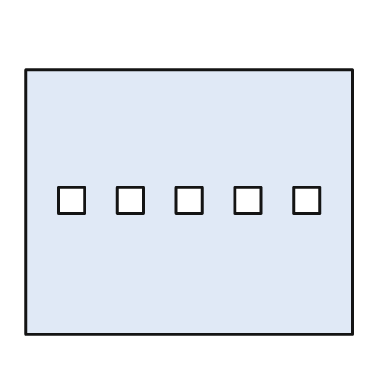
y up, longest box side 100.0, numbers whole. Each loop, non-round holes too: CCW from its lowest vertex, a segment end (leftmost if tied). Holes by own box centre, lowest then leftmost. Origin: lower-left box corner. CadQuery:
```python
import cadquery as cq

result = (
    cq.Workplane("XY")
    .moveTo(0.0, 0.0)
    .lineTo(100.0, 0.0)
    .lineTo(100.0, 81.0)
    .lineTo(0.0, 81.0)
    .close()
    .moveTo(10.0, 37.0)
    .lineTo(18.0, 37.0)
    .lineTo(18.0, 45.0)
    .lineTo(10.0, 45.0)
    .close()
    .moveTo(28.0, 37.0)
    .lineTo(36.0, 37.0)
    .lineTo(36.0, 45.0)
    .lineTo(28.0, 45.0)
    .close()
    .moveTo(46.0, 37.0)
    .lineTo(54.0, 37.0)
    .lineTo(54.0, 45.0)
    .lineTo(46.0, 45.0)
    .close()
    .moveTo(64.0, 37.0)
    .lineTo(72.0, 37.0)
    .lineTo(72.0, 45.0)
    .lineTo(64.0, 45.0)
    .close()
    .moveTo(82.0, 37.0)
    .lineTo(90.0, 37.0)
    .lineTo(90.0, 45.0)
    .lineTo(82.0, 45.0)
    .close()
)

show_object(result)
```